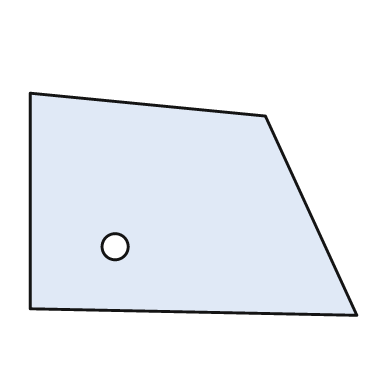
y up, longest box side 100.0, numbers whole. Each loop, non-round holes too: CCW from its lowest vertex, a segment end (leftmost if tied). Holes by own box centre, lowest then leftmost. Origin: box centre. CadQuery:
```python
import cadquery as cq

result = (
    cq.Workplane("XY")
    .moveTo(50.0, -34.0)
    .lineTo(22.0, 27.0)
    .lineTo(-50.0, 34.0)
    .lineTo(-50.0, -32.0)
    .close()
    .moveTo(-24.0, -13.0)
    .circle(4.0)
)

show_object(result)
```